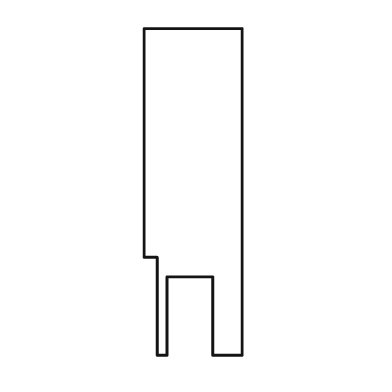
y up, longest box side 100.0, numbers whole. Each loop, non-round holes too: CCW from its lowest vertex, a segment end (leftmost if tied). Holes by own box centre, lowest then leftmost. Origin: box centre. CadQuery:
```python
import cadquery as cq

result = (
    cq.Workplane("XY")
    .moveTo(-11.0, -50.0)
    .lineTo(-8.0, -50.0)
    .lineTo(-8.0, -26.0)
    .lineTo(6.0, -26.0)
    .lineTo(6.0, -50.0)
    .lineTo(15.0, -50.0)
    .lineTo(15.0, 50.0)
    .lineTo(-15.0, 50.0)
    .lineTo(-15.0, -20.0)
    .lineTo(-11.0, -20.0)
    .close()
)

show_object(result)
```